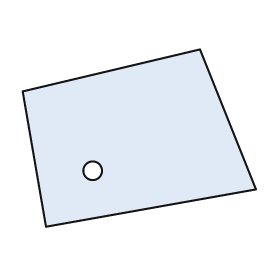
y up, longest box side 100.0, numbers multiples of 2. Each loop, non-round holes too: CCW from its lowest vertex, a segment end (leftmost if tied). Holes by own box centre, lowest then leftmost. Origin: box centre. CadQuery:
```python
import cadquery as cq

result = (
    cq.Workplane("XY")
    .moveTo(-40.0, -38.0)
    .lineTo(50.0, -22.0)
    .lineTo(26.0, 38.0)
    .lineTo(-50.0, 20.0)
    .close()
    .moveTo(-20.0, -14.0)
    .circle(4.0)
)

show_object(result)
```